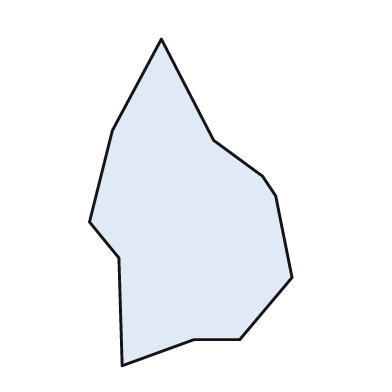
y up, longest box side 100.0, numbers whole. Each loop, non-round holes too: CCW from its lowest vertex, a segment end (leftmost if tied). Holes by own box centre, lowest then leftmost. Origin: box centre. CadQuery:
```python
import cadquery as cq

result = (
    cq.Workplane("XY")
    .moveTo(-21.0, -50.0)
    .lineTo(1.0, -42.0)
    .lineTo(15.0, -42.0)
    .lineTo(31.0, -23.0)
    .lineTo(26.0, 2.0)
    .lineTo(22.0, 8.0)
    .lineTo(7.0, 19.0)
    .lineTo(-9.0, 50.0)
    .lineTo(-24.0, 22.0)
    .lineTo(-31.0, -6.0)
    .lineTo(-22.0, -17.0)
    .close()
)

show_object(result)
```